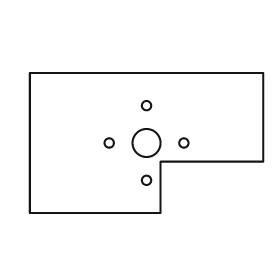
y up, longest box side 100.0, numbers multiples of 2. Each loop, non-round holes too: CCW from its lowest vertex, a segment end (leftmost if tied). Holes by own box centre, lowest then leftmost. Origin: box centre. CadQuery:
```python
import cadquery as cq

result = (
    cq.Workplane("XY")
    .moveTo(-50.0, -30.0)
    .lineTo(6.0, -30.0)
    .lineTo(6.0, -8.0)
    .lineTo(50.0, -8.0)
    .lineTo(50.0, 30.0)
    .lineTo(-50.0, 30.0)
    .close()
    .moveTo(0.0, -16.0)
    .circle(2.0)
    .moveTo(-16.0, 0.0)
    .circle(2.0)
    .moveTo(0.0, 0.0)
    .circle(6.0)
    .moveTo(16.0, 0.0)
    .circle(2.0)
    .moveTo(0.0, 16.0)
    .circle(2.0)
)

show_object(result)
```